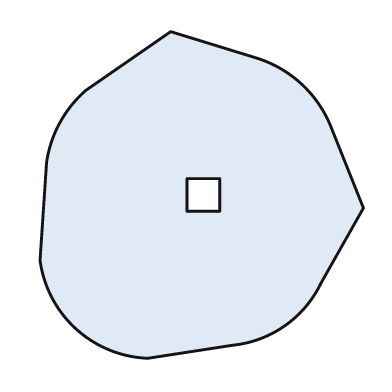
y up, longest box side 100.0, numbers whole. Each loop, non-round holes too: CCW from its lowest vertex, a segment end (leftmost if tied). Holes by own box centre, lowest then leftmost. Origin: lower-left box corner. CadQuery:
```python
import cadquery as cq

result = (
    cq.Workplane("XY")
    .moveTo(33.0, 0.0)
    .lineTo(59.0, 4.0)
    .threePointArc((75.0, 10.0), (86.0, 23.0))
    .lineTo(99.0, 46.0)
    .lineTo(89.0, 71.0)
    .threePointArc((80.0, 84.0), (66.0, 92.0))
    .lineTo(40.0, 100.0)
    .lineTo(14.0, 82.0)
    .threePointArc((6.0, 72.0), (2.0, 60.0))
    .lineTo(0.0, 30.0)
    .threePointArc((11.0, 9.0), (33.0, 0.0))
    .close()
    .moveTo(45.0, 45.0)
    .lineTo(55.0, 45.0)
    .lineTo(55.0, 55.0)
    .lineTo(45.0, 55.0)
    .close()
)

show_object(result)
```